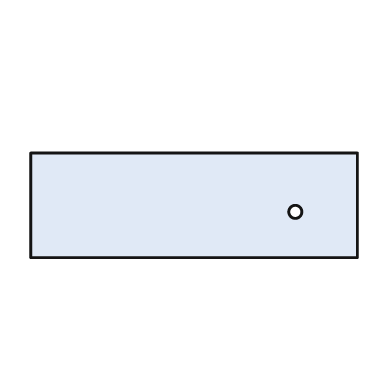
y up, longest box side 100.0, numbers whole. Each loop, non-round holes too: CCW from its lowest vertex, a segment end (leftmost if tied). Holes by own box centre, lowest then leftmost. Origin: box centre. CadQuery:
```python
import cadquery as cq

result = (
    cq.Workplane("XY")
    .moveTo(-50.0, -16.0)
    .lineTo(50.0, -16.0)
    .lineTo(50.0, 16.0)
    .lineTo(-50.0, 16.0)
    .close()
    .moveTo(31.0, -2.0)
    .circle(2.0)
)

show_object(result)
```